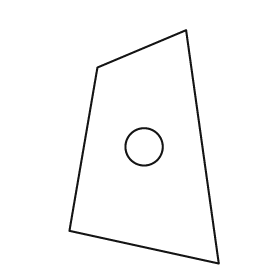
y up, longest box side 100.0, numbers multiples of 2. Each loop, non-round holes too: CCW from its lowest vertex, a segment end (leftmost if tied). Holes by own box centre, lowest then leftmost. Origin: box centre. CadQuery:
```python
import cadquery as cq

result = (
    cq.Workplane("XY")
    .moveTo(32.0, -50.0)
    .lineTo(18.0, 50.0)
    .lineTo(-20.0, 34.0)
    .lineTo(-32.0, -36.0)
    .close()
    .moveTo(0.0, 0.0)
    .circle(8.0)
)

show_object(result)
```